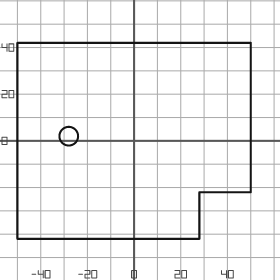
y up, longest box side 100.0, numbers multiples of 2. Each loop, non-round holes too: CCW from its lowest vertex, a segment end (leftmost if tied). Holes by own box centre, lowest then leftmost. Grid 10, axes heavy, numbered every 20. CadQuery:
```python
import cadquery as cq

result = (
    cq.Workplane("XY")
    .moveTo(-50.0, -42.0)
    .lineTo(28.0, -42.0)
    .lineTo(28.0, -22.0)
    .lineTo(50.0, -22.0)
    .lineTo(50.0, 42.0)
    .lineTo(-50.0, 42.0)
    .close()
    .moveTo(-28.0, 2.0)
    .circle(4.0)
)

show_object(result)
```